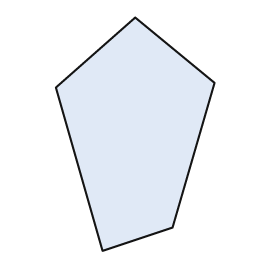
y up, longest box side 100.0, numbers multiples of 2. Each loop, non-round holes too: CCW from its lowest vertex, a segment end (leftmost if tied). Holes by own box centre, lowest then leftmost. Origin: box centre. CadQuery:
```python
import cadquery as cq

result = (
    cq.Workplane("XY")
    .moveTo(-14.0, -50.0)
    .lineTo(16.0, -40.0)
    .lineTo(34.0, 22.0)
    .lineTo(0.0, 50.0)
    .lineTo(-34.0, 20.0)
    .close()
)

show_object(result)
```